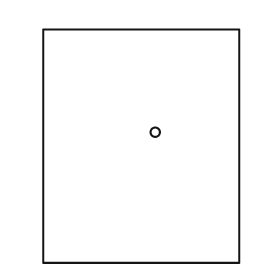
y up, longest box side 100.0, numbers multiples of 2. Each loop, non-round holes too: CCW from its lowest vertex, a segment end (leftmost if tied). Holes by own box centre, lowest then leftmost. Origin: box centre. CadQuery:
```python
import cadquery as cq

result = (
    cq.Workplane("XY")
    .moveTo(-42.0, -50.0)
    .lineTo(42.0, -50.0)
    .lineTo(42.0, 50.0)
    .lineTo(-42.0, 50.0)
    .close()
    .moveTo(6.0, 6.0)
    .circle(2.0)
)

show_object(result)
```